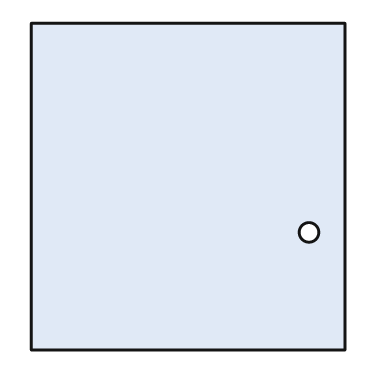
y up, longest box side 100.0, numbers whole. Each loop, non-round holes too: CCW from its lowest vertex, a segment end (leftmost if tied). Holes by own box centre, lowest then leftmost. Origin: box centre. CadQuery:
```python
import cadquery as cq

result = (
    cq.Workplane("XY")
    .moveTo(-48.0, -50.0)
    .lineTo(48.0, -50.0)
    .lineTo(48.0, 50.0)
    .lineTo(-48.0, 50.0)
    .close()
    .moveTo(37.0, -14.0)
    .circle(3.0)
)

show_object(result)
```